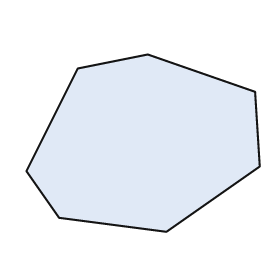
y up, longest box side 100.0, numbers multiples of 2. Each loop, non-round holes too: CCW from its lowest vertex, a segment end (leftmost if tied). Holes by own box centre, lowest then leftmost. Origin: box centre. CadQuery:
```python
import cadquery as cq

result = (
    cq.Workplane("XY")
    .moveTo(10.0, -38.0)
    .lineTo(50.0, -10.0)
    .lineTo(48.0, 22.0)
    .lineTo(2.0, 38.0)
    .lineTo(-28.0, 32.0)
    .lineTo(-50.0, -12.0)
    .lineTo(-36.0, -32.0)
    .close()
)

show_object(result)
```